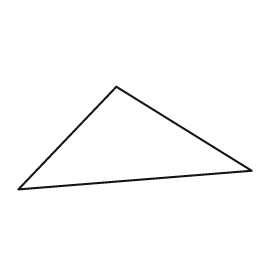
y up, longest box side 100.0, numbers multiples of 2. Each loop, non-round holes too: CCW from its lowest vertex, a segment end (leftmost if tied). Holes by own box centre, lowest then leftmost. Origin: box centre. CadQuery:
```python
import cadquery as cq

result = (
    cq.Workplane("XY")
    .moveTo(-50.0, -22.0)
    .lineTo(50.0, -14.0)
    .lineTo(-8.0, 22.0)
    .close()
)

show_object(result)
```